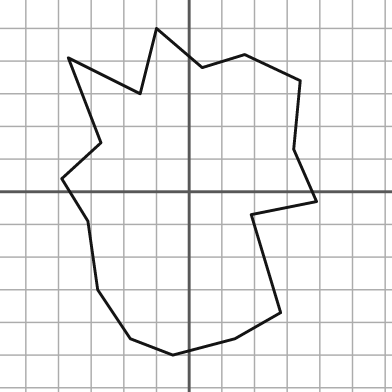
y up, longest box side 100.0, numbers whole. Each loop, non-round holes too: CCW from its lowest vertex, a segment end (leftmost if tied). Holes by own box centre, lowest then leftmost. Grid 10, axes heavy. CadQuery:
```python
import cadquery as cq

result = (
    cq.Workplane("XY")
    .moveTo(-5.0, -50.0)
    .lineTo(14.0, -45.0)
    .lineTo(28.0, -37.0)
    .lineTo(19.0, -7.0)
    .lineTo(39.0, -3.0)
    .lineTo(32.0, 13.0)
    .lineTo(34.0, 34.0)
    .lineTo(17.0, 42.0)
    .lineTo(4.0, 38.0)
    .lineTo(-10.0, 50.0)
    .lineTo(-15.0, 30.0)
    .lineTo(-37.0, 41.0)
    .lineTo(-27.0, 15.0)
    .lineTo(-39.0, 4.0)
    .lineTo(-31.0, -9.0)
    .lineTo(-28.0, -30.0)
    .lineTo(-18.0, -45.0)
    .close()
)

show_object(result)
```